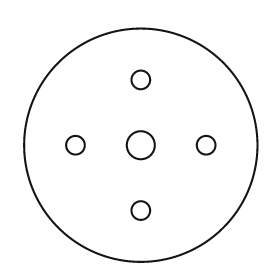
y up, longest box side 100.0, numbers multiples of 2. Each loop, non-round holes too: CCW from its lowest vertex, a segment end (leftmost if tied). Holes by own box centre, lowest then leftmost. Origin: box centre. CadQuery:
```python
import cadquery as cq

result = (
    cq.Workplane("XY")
    .moveTo(0.0, 0.0)
    .circle(50.0)
    .moveTo(0.0, -28.0)
    .circle(4.0)
    .moveTo(-28.0, 0.0)
    .circle(4.0)
    .moveTo(0.0, 0.0)
    .circle(6.0)
    .moveTo(28.0, 0.0)
    .circle(4.0)
    .moveTo(0.0, 28.0)
    .circle(4.0)
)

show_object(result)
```